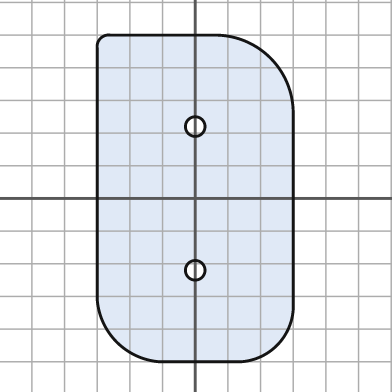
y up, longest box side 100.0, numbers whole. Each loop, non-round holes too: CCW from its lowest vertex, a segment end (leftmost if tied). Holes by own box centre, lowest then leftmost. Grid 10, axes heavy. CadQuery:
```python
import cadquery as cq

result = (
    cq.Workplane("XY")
    .moveTo(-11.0, -50.0)
    .lineTo(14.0, -50.0)
    .threePointArc((25.0, -45.0), (30.0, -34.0))
    .lineTo(30.0, 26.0)
    .threePointArc((23.0, 43.0), (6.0, 50.0))
    .lineTo(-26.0, 50.0)
    .threePointArc((-29.0, 49.0), (-30.0, 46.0))
    .lineTo(-30.0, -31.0)
    .threePointArc((-24.0, -44.0), (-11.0, -50.0))
    .close()
    .moveTo(0.0, -22.0)
    .circle(3.0)
    .moveTo(0.0, 22.0)
    .circle(3.0)
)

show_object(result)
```